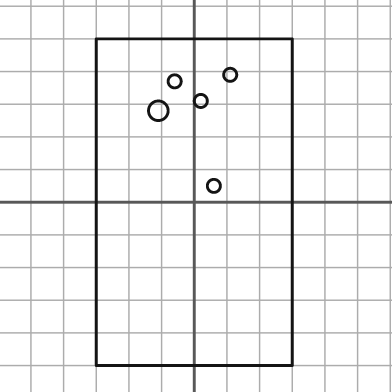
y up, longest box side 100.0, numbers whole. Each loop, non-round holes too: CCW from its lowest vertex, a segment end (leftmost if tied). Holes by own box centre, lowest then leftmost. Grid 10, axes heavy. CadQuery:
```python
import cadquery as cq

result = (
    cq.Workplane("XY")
    .moveTo(-30.0, -50.0)
    .lineTo(30.0, -50.0)
    .lineTo(30.0, 50.0)
    .lineTo(-30.0, 50.0)
    .close()
    .moveTo(6.0, 5.0)
    .circle(2.0)
    .moveTo(-11.0, 28.0)
    .circle(3.0)
    .moveTo(2.0, 31.0)
    .circle(2.0)
    .moveTo(-6.0, 37.0)
    .circle(2.0)
    .moveTo(11.0, 39.0)
    .circle(2.0)
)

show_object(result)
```